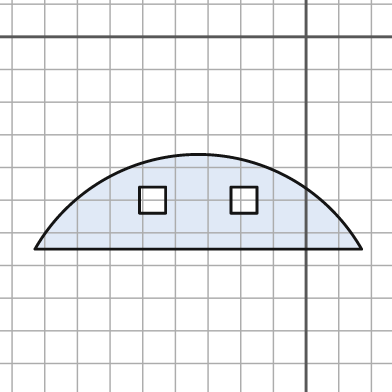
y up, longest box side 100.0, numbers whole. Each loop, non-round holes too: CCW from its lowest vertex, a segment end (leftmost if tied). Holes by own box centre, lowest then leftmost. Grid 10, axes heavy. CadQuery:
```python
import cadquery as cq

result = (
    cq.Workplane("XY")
    .moveTo(-83.0, -65.0)
    .lineTo(17.0, -65.0)
    .threePointArc((-33.0, -36.0), (-83.0, -65.0))
    .close()
    .moveTo(-51.0, -54.0)
    .lineTo(-43.0, -54.0)
    .lineTo(-43.0, -46.0)
    .lineTo(-51.0, -46.0)
    .close()
    .moveTo(-23.0, -54.0)
    .lineTo(-15.0, -54.0)
    .lineTo(-15.0, -46.0)
    .lineTo(-23.0, -46.0)
    .close()
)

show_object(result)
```